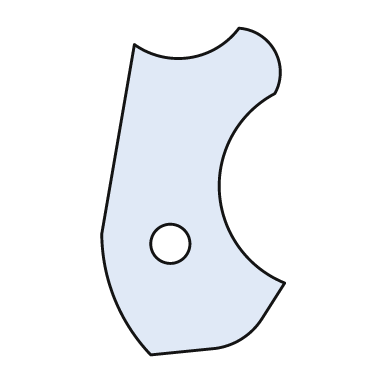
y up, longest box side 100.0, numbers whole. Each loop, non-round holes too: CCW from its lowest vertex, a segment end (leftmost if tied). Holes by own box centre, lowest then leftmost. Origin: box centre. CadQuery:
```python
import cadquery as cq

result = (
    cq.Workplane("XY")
    .moveTo(-13.0, -50.0)
    .lineTo(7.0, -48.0)
    .threePointArc((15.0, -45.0), (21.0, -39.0))
    .lineTo(28.0, -28.0)
    .threePointArc((8.0, 0.0), (25.0, 30.0))
    .threePointArc((25.0, 43.0), (14.0, 50.0))
    .threePointArc((-1.0, 41.0), (-18.0, 45.0))
    .lineTo(-28.0, -13.0)
    .threePointArc((-24.0, -33.0), (-13.0, -50.0))
    .close()
    .moveTo(-7.0, -16.0)
    .circle(6.0)
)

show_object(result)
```